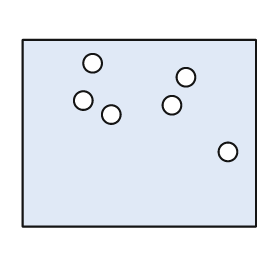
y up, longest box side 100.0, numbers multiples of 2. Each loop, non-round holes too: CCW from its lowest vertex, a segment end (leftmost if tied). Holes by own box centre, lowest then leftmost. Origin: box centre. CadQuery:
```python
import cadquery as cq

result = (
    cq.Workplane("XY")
    .moveTo(-50.0, -40.0)
    .lineTo(50.0, -40.0)
    .lineTo(50.0, 40.0)
    .lineTo(-50.0, 40.0)
    .close()
    .moveTo(38.0, -8.0)
    .circle(4.0)
    .moveTo(-12.0, 8.0)
    .circle(4.0)
    .moveTo(14.0, 12.0)
    .circle(4.0)
    .moveTo(-24.0, 14.0)
    .circle(4.0)
    .moveTo(20.0, 24.0)
    .circle(4.0)
    .moveTo(-20.0, 30.0)
    .circle(4.0)
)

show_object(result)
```